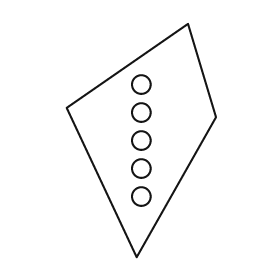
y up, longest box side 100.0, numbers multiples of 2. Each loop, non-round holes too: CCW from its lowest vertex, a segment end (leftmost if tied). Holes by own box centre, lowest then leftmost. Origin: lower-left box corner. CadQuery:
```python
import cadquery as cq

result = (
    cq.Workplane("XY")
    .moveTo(30.0, 0.0)
    .lineTo(64.0, 60.0)
    .lineTo(52.0, 100.0)
    .lineTo(0.0, 64.0)
    .close()
    .moveTo(32.0, 26.0)
    .circle(4.0)
    .moveTo(32.0, 38.0)
    .circle(4.0)
    .moveTo(32.0, 50.0)
    .circle(4.0)
    .moveTo(32.0, 62.0)
    .circle(4.0)
    .moveTo(32.0, 74.0)
    .circle(4.0)
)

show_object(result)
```